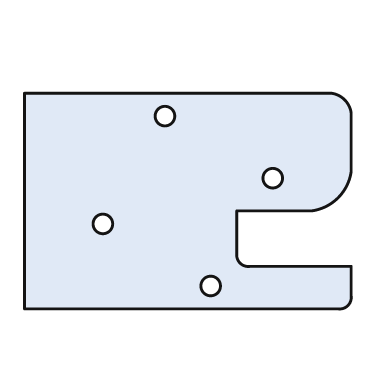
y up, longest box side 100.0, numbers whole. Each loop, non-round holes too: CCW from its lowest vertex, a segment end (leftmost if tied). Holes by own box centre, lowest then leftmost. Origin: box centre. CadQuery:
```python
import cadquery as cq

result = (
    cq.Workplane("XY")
    .moveTo(-50.0, -33.0)
    .lineTo(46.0, -33.0)
    .threePointArc((49.0, -32.0), (50.0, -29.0))
    .lineTo(50.0, -20.0)
    .lineTo(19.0, -20.0)
    .threePointArc((16.0, -19.0), (15.0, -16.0))
    .lineTo(15.0, -3.0)
    .lineTo(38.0, -3.0)
    .threePointArc((46.0, 1.0), (50.0, 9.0))
    .lineTo(50.0, 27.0)
    .threePointArc((48.0, 31.0), (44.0, 33.0))
    .lineTo(-50.0, 33.0)
    .close()
    .moveTo(7.0, -26.0)
    .circle(3.0)
    .moveTo(-26.0, -7.0)
    .circle(3.0)
    .moveTo(26.0, 7.0)
    .circle(3.0)
    .moveTo(-7.0, 26.0)
    .circle(3.0)
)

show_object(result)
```